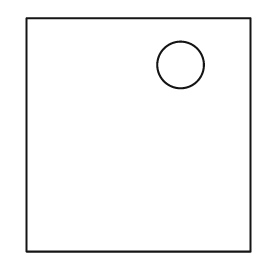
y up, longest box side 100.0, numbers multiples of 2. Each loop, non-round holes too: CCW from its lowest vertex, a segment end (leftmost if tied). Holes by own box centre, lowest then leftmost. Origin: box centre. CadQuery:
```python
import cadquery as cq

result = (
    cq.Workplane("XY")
    .moveTo(-48.0, -50.0)
    .lineTo(48.0, -50.0)
    .lineTo(48.0, 50.0)
    .lineTo(-48.0, 50.0)
    .close()
    .moveTo(18.0, 30.0)
    .circle(10.0)
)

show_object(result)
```